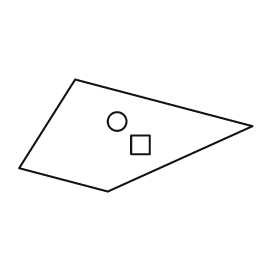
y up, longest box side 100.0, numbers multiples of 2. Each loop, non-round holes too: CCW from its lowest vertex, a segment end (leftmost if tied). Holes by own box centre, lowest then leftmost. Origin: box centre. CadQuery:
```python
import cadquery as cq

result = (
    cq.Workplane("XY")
    .moveTo(-12.0, -24.0)
    .lineTo(50.0, 4.0)
    .lineTo(-26.0, 24.0)
    .lineTo(-50.0, -14.0)
    .close()
    .moveTo(-2.0, -8.0)
    .lineTo(6.0, -8.0)
    .lineTo(6.0, 0.0)
    .lineTo(-2.0, 0.0)
    .close()
    .moveTo(-8.0, 6.0)
    .circle(4.0)
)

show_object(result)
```